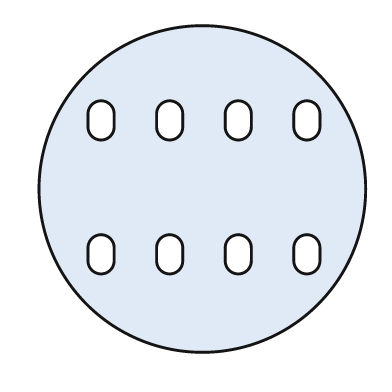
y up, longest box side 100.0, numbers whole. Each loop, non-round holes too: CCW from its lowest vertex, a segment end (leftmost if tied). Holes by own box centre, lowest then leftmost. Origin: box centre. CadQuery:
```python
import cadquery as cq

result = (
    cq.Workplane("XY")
    .moveTo(0.0, 0.0)
    .circle(50.0)
    .moveTo(-35.0, -22.0)
    .threePointArc((-31.0, -26.0), (-27.0, -22.0))
    .lineTo(-27.0, -18.0)
    .threePointArc((-31.0, -14.0), (-35.0, -18.0))
    .close()
    .moveTo(-14.0, -22.0)
    .threePointArc((-10.0, -26.0), (-6.0, -22.0))
    .lineTo(-6.0, -18.0)
    .threePointArc((-10.0, -14.0), (-14.0, -18.0))
    .close()
    .moveTo(7.0, -22.0)
    .threePointArc((11.0, -26.0), (15.0, -22.0))
    .lineTo(15.0, -18.0)
    .threePointArc((11.0, -14.0), (7.0, -18.0))
    .close()
    .moveTo(28.0, -22.0)
    .threePointArc((32.0, -26.0), (36.0, -22.0))
    .lineTo(36.0, -18.0)
    .threePointArc((32.0, -14.0), (28.0, -18.0))
    .close()
    .moveTo(-35.0, 19.0)
    .threePointArc((-31.0, 15.0), (-27.0, 19.0))
    .lineTo(-27.0, 23.0)
    .threePointArc((-31.0, 27.0), (-35.0, 23.0))
    .close()
    .moveTo(-14.0, 19.0)
    .threePointArc((-10.0, 15.0), (-6.0, 19.0))
    .lineTo(-6.0, 23.0)
    .threePointArc((-10.0, 27.0), (-14.0, 23.0))
    .close()
    .moveTo(7.0, 19.0)
    .threePointArc((11.0, 15.0), (15.0, 19.0))
    .lineTo(15.0, 23.0)
    .threePointArc((11.0, 27.0), (7.0, 23.0))
    .close()
    .moveTo(28.0, 19.0)
    .threePointArc((32.0, 15.0), (36.0, 19.0))
    .lineTo(36.0, 23.0)
    .threePointArc((32.0, 27.0), (28.0, 23.0))
    .close()
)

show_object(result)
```